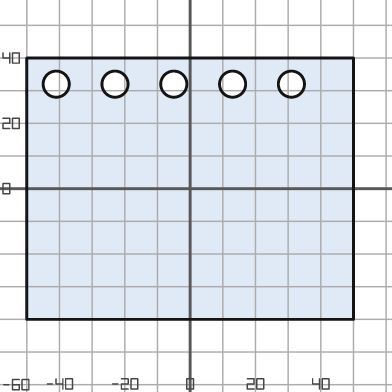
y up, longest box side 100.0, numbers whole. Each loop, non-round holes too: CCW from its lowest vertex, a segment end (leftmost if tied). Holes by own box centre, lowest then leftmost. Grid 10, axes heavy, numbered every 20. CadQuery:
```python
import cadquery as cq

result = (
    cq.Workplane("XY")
    .moveTo(-50.0, -40.0)
    .lineTo(50.0, -40.0)
    .lineTo(50.0, 40.0)
    .lineTo(-50.0, 40.0)
    .close()
    .moveTo(-41.0, 32.0)
    .circle(4.0)
    .moveTo(-23.0, 32.0)
    .circle(4.0)
    .moveTo(-5.0, 32.0)
    .circle(4.0)
    .moveTo(13.0, 32.0)
    .circle(4.0)
    .moveTo(31.0, 32.0)
    .circle(4.0)
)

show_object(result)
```